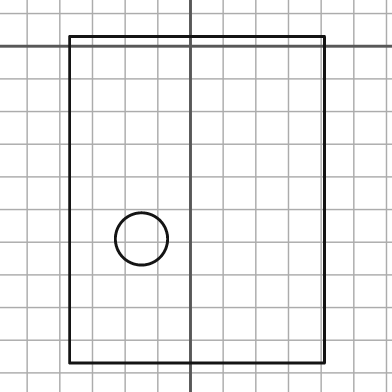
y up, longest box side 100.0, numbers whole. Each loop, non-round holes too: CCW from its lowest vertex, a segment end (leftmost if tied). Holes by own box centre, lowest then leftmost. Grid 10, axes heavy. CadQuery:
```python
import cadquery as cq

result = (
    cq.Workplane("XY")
    .moveTo(-37.0, -97.0)
    .lineTo(41.0, -97.0)
    .lineTo(41.0, 3.0)
    .lineTo(-37.0, 3.0)
    .close()
    .moveTo(-15.0, -59.0)
    .circle(8.0)
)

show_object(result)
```